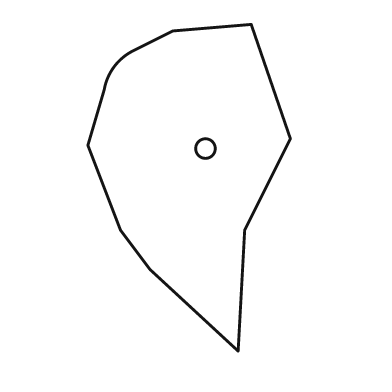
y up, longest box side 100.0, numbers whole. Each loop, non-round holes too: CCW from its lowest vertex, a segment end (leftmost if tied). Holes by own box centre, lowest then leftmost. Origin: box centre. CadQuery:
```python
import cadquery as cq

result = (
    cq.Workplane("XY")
    .moveTo(15.0, -50.0)
    .lineTo(17.0, -13.0)
    .lineTo(31.0, 15.0)
    .lineTo(19.0, 50.0)
    .lineTo(-5.0, 48.0)
    .lineTo(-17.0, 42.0)
    .threePointArc((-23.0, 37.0), (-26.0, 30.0))
    .lineTo(-31.0, 13.0)
    .lineTo(-21.0, -13.0)
    .lineTo(-12.0, -25.0)
    .close()
    .moveTo(5.0, 12.0)
    .circle(3.0)
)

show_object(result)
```